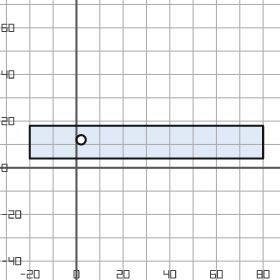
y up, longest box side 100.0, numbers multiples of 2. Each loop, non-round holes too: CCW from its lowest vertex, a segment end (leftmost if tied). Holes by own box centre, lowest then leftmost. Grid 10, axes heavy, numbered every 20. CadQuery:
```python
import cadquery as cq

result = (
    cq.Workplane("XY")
    .moveTo(-20.0, 4.0)
    .lineTo(80.0, 4.0)
    .lineTo(80.0, 18.0)
    .lineTo(-20.0, 18.0)
    .close()
    .moveTo(2.0, 12.0)
    .circle(2.0)
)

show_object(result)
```